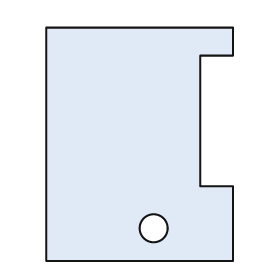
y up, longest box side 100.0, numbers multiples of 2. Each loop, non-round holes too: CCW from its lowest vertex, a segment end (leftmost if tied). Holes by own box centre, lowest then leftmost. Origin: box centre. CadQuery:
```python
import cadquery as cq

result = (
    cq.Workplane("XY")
    .moveTo(-40.0, -50.0)
    .lineTo(40.0, -50.0)
    .lineTo(40.0, -18.0)
    .lineTo(26.0, -18.0)
    .lineTo(26.0, 38.0)
    .lineTo(40.0, 38.0)
    .lineTo(40.0, 50.0)
    .lineTo(-40.0, 50.0)
    .close()
    .moveTo(6.0, -36.0)
    .circle(6.0)
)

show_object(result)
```